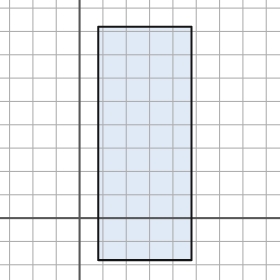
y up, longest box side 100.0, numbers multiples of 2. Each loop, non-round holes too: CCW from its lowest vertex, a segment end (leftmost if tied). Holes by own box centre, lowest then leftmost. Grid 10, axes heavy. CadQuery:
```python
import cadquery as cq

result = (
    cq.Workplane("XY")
    .moveTo(8.0, -18.0)
    .lineTo(48.0, -18.0)
    .lineTo(48.0, 82.0)
    .lineTo(8.0, 82.0)
    .close()
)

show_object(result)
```